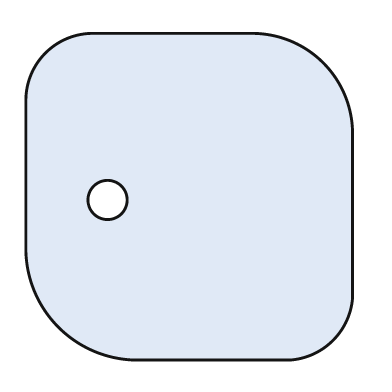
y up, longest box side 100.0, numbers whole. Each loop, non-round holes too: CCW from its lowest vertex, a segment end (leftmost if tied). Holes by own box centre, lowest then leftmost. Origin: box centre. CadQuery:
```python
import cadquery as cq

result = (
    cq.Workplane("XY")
    .moveTo(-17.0, -50.0)
    .lineTo(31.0, -50.0)
    .threePointArc((44.0, -44.0), (50.0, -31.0))
    .lineTo(50.0, 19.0)
    .threePointArc((41.0, 41.0), (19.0, 50.0))
    .lineTo(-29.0, 50.0)
    .threePointArc((-44.0, 44.0), (-50.0, 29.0))
    .lineTo(-50.0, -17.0)
    .threePointArc((-40.0, -40.0), (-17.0, -50.0))
    .close()
    .moveTo(-25.0, -1.0)
    .circle(6.0)
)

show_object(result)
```